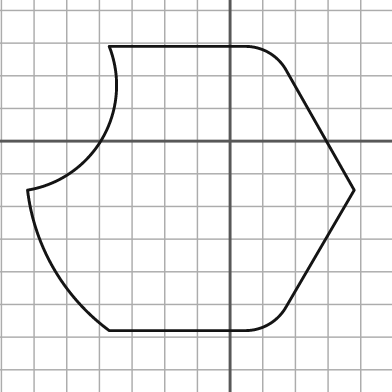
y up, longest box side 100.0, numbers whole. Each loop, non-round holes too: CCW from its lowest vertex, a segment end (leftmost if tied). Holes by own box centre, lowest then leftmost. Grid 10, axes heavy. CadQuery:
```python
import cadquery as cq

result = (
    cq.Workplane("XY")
    .moveTo(-37.0, -58.0)
    .lineTo(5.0, -58.0)
    .threePointArc((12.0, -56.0), (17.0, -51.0))
    .lineTo(38.0, -15.0)
    .lineTo(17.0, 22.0)
    .threePointArc((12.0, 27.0), (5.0, 29.0))
    .lineTo(-37.0, 29.0)
    .threePointArc((-39.0, 1.0), (-62.0, -15.0))
    .threePointArc((-54.0, -39.0), (-37.0, -58.0))
    .close()
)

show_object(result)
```